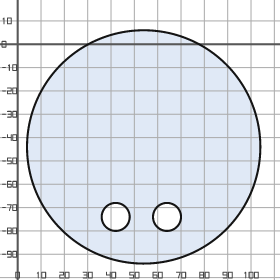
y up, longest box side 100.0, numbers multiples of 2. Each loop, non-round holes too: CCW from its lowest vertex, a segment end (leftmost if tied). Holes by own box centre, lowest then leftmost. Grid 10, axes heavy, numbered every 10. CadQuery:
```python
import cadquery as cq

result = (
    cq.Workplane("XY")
    .moveTo(54.0, -44.0)
    .circle(50.0)
    .moveTo(42.0, -74.0)
    .circle(6.0)
    .moveTo(64.0, -74.0)
    .circle(6.0)
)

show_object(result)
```